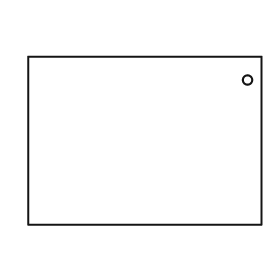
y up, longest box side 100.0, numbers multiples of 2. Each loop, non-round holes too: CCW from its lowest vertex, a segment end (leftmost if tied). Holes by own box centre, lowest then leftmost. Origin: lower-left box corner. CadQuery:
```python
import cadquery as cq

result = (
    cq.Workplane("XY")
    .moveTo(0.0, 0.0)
    .lineTo(100.0, 0.0)
    .lineTo(100.0, 72.0)
    .lineTo(0.0, 72.0)
    .close()
    .moveTo(94.0, 62.0)
    .circle(2.0)
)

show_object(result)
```